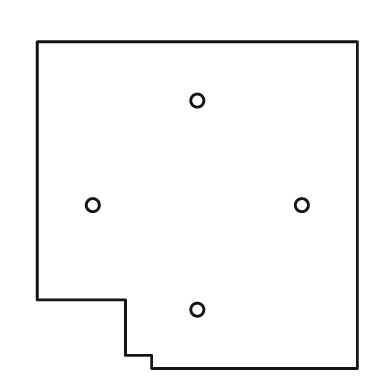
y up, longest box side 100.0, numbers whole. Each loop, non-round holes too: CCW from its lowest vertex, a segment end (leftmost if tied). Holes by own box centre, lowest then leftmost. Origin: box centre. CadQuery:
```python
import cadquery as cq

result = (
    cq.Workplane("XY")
    .moveTo(-14.0, -50.0)
    .lineTo(49.0, -50.0)
    .lineTo(49.0, 50.0)
    .lineTo(-49.0, 50.0)
    .lineTo(-49.0, -29.0)
    .lineTo(-22.0, -29.0)
    .lineTo(-22.0, -46.0)
    .lineTo(-14.0, -46.0)
    .close()
    .moveTo(0.0, -32.0)
    .circle(2.0)
    .moveTo(-32.0, 0.0)
    .circle(2.0)
    .moveTo(32.0, 0.0)
    .circle(2.0)
    .moveTo(0.0, 32.0)
    .circle(2.0)
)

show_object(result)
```